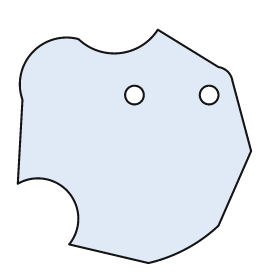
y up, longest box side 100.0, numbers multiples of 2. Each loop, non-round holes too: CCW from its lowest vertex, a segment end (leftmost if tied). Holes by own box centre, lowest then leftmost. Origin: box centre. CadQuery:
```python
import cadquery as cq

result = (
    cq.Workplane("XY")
    .moveTo(6.0, -50.0)
    .threePointArc((22.0, -44.0), (36.0, -34.0))
    .lineTo(50.0, -2.0)
    .lineTo(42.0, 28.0)
    .threePointArc((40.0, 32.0), (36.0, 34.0))
    .lineTo(10.0, 50.0)
    .threePointArc((-6.0, 40.0), (-24.0, 46.0))
    .threePointArc((-44.0, 40.0), (-48.0, 20.0))
    .lineTo(-50.0, -16.0)
    .threePointArc((-28.0, -20.0), (-28.0, -42.0))
    .close()
    .moveTo(0.0, 22.0)
    .circle(4.0)
    .moveTo(32.0, 22.0)
    .circle(4.0)
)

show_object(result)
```